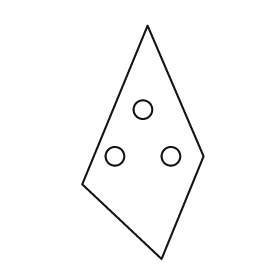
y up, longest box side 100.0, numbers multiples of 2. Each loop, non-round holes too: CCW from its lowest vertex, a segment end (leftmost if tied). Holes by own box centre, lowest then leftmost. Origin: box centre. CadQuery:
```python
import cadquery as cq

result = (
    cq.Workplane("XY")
    .moveTo(8.0, -50.0)
    .lineTo(26.0, -6.0)
    .lineTo(2.0, 50.0)
    .lineTo(-26.0, -18.0)
    .close()
    .moveTo(-12.0, -6.0)
    .circle(4.0)
    .moveTo(12.0, -6.0)
    .circle(4.0)
    .moveTo(0.0, 14.0)
    .circle(4.0)
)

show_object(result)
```